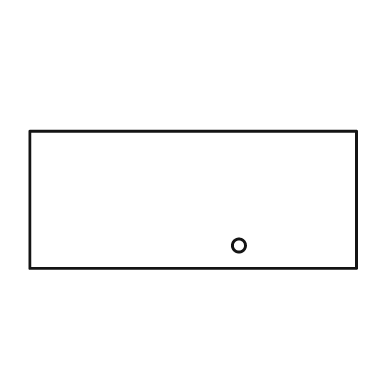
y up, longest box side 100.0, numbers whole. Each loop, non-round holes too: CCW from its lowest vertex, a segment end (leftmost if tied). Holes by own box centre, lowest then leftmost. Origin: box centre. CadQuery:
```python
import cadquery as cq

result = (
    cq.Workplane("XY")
    .moveTo(-50.0, -21.0)
    .lineTo(50.0, -21.0)
    .lineTo(50.0, 21.0)
    .lineTo(-50.0, 21.0)
    .close()
    .moveTo(14.0, -14.0)
    .circle(2.0)
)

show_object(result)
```